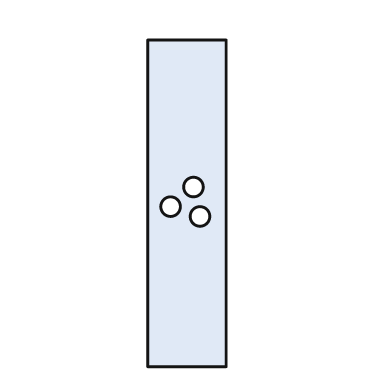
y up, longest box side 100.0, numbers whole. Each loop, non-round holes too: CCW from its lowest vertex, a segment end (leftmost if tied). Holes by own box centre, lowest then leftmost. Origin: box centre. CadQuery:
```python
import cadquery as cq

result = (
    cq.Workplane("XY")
    .moveTo(-12.0, -50.0)
    .lineTo(12.0, -50.0)
    .lineTo(12.0, 50.0)
    .lineTo(-12.0, 50.0)
    .close()
    .moveTo(4.0, -4.0)
    .circle(3.0)
    .moveTo(-5.0, -1.0)
    .circle(3.0)
    .moveTo(2.0, 5.0)
    .circle(3.0)
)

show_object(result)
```